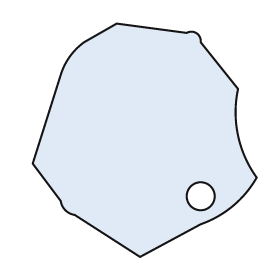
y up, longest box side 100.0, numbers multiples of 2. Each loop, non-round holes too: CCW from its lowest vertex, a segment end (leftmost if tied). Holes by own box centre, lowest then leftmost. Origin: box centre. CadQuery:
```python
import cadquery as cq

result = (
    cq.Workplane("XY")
    .moveTo(-2.0, -50.0)
    .lineTo(24.0, -36.0)
    .threePointArc((38.0, -28.0), (48.0, -16.0))
    .threePointArc((40.0, 2.0), (40.0, 22.0))
    .lineTo(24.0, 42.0)
    .threePointArc((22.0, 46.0), (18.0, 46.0))
    .lineTo(-12.0, 50.0)
    .lineTo(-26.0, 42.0)
    .threePointArc((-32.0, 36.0), (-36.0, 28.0))
    .lineTo(-48.0, -10.0)
    .lineTo(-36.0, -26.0)
    .threePointArc((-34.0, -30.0), (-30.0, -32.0))
    .close()
    .moveTo(24.0, -24.0)
    .circle(6.0)
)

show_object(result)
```